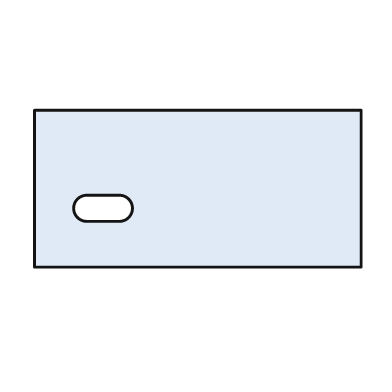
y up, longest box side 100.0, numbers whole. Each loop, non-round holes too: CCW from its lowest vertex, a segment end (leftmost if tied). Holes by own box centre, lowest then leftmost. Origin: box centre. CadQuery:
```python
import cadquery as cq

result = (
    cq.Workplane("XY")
    .moveTo(-50.0, -24.0)
    .lineTo(50.0, -24.0)
    .lineTo(50.0, 24.0)
    .lineTo(-50.0, 24.0)
    .close()
    .moveTo(-34.0, -10.0)
    .lineTo(-24.0, -10.0)
    .threePointArc((-20.0, -6.0), (-24.0, -2.0))
    .lineTo(-34.0, -2.0)
    .threePointArc((-38.0, -6.0), (-34.0, -10.0))
    .close()
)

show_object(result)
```